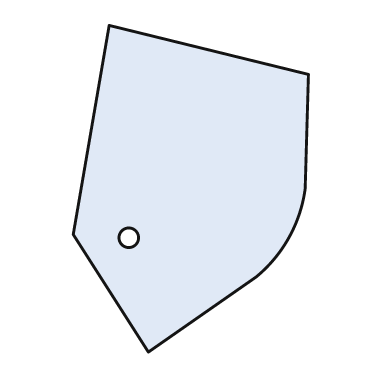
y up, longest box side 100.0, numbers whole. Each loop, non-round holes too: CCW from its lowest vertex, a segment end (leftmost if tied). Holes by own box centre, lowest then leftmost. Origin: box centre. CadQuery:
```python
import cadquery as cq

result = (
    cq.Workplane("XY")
    .moveTo(-13.0, -50.0)
    .lineTo(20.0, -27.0)
    .threePointArc((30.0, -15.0), (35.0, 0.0))
    .lineTo(36.0, 35.0)
    .lineTo(-25.0, 50.0)
    .lineTo(-36.0, -14.0)
    .close()
    .moveTo(-19.0, -15.0)
    .circle(3.0)
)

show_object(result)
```